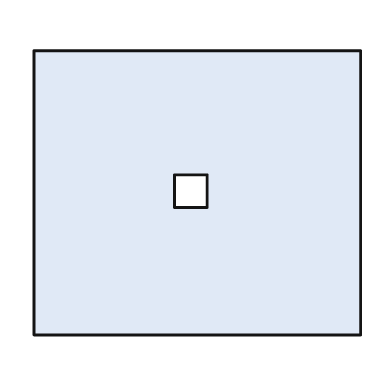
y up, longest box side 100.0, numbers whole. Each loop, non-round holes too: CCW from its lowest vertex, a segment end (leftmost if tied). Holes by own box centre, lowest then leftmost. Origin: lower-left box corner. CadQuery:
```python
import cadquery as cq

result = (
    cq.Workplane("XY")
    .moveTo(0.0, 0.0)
    .lineTo(100.0, 0.0)
    .lineTo(100.0, 87.0)
    .lineTo(0.0, 87.0)
    .close()
    .moveTo(43.0, 39.0)
    .lineTo(53.0, 39.0)
    .lineTo(53.0, 49.0)
    .lineTo(43.0, 49.0)
    .close()
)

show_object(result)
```